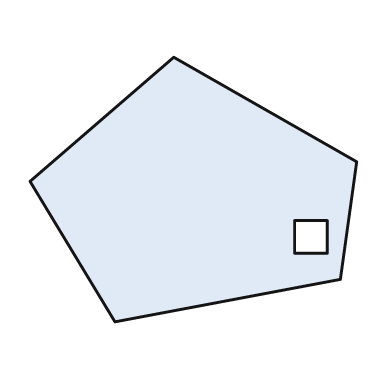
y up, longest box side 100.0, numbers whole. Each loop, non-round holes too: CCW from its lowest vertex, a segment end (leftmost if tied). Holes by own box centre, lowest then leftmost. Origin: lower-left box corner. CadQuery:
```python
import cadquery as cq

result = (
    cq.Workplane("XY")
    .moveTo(26.0, 0.0)
    .lineTo(95.0, 13.0)
    .lineTo(100.0, 49.0)
    .lineTo(44.0, 81.0)
    .lineTo(0.0, 43.0)
    .close()
    .moveTo(81.0, 21.0)
    .lineTo(91.0, 21.0)
    .lineTo(91.0, 31.0)
    .lineTo(81.0, 31.0)
    .close()
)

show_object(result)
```